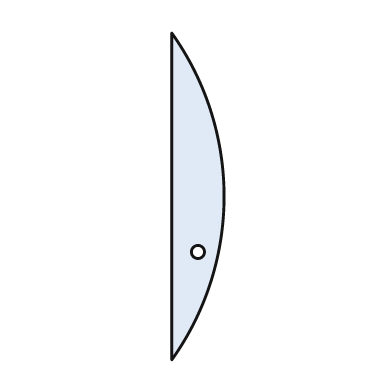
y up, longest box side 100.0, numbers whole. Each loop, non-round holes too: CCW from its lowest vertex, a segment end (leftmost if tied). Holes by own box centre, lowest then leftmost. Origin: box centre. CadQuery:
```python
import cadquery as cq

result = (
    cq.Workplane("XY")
    .moveTo(-8.0, -50.0)
    .threePointArc((8.0, 0.0), (-8.0, 50.0))
    .close()
    .moveTo(0.0, -17.0)
    .circle(2.0)
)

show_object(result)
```